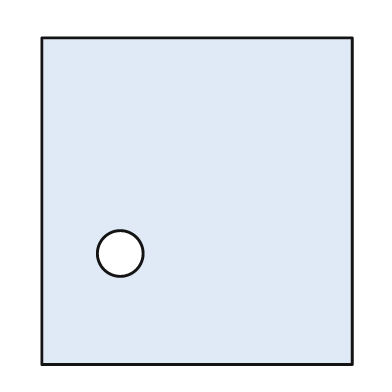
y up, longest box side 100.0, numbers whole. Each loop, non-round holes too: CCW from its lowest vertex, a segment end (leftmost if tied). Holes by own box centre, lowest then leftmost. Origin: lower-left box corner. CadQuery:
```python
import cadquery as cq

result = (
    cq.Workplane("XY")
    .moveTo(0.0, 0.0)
    .lineTo(95.0, 0.0)
    .lineTo(95.0, 100.0)
    .lineTo(0.0, 100.0)
    .close()
    .moveTo(24.0, 34.0)
    .circle(7.0)
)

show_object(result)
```